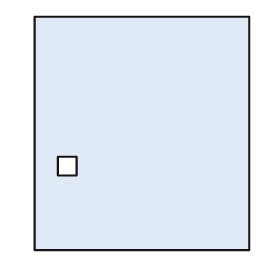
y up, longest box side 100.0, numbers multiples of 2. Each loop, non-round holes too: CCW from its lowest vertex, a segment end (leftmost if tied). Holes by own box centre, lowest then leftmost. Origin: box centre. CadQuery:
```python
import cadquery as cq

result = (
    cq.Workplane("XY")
    .moveTo(-46.0, -50.0)
    .lineTo(46.0, -50.0)
    .lineTo(46.0, 50.0)
    .lineTo(-46.0, 50.0)
    .close()
    .moveTo(-36.0, -18.0)
    .lineTo(-28.0, -18.0)
    .lineTo(-28.0, -10.0)
    .lineTo(-36.0, -10.0)
    .close()
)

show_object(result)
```